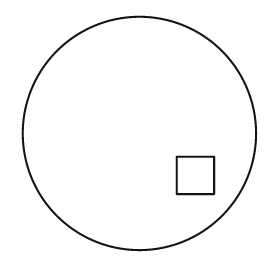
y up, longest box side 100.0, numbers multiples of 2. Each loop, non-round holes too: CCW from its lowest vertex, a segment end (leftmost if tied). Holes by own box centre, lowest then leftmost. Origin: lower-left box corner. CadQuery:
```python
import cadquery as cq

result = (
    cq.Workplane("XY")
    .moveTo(50.0, 50.0)
    .circle(50.0)
    .moveTo(66.0, 24.0)
    .lineTo(82.0, 24.0)
    .lineTo(82.0, 40.0)
    .lineTo(66.0, 40.0)
    .close()
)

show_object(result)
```